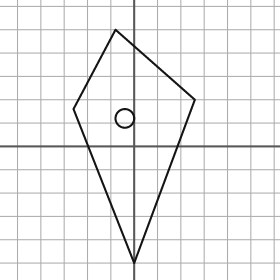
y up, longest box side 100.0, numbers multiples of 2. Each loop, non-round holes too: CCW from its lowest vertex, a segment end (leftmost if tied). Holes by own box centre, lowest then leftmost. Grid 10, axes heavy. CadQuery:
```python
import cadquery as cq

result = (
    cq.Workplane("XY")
    .moveTo(0.0, -50.0)
    .lineTo(26.0, 20.0)
    .lineTo(-8.0, 50.0)
    .lineTo(-26.0, 16.0)
    .close()
    .moveTo(-4.0, 12.0)
    .circle(4.0)
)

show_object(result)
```